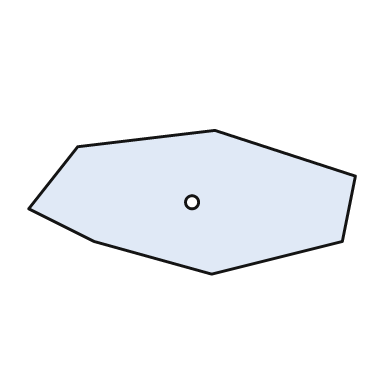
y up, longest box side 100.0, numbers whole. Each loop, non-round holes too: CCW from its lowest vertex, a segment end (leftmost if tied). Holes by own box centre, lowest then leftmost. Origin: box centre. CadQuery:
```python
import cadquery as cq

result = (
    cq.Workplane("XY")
    .moveTo(6.0, -22.0)
    .lineTo(46.0, -12.0)
    .lineTo(50.0, 8.0)
    .lineTo(7.0, 22.0)
    .lineTo(-35.0, 17.0)
    .lineTo(-50.0, -2.0)
    .lineTo(-30.0, -12.0)
    .close()
    .moveTo(0.0, 0.0)
    .circle(2.0)
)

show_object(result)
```